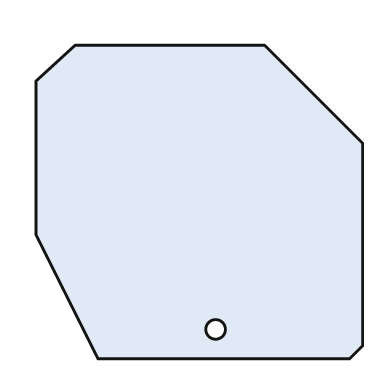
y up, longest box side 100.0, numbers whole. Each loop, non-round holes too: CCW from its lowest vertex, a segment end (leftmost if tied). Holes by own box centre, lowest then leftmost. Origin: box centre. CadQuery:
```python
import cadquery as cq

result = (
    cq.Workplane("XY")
    .moveTo(-31.0, -48.0)
    .lineTo(46.0, -48.0)
    .lineTo(50.0, -44.0)
    .lineTo(50.0, 18.0)
    .lineTo(20.0, 48.0)
    .lineTo(-38.0, 48.0)
    .lineTo(-50.0, 37.0)
    .lineTo(-50.0, -10.0)
    .close()
    .moveTo(5.0, -39.0)
    .circle(3.0)
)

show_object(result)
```